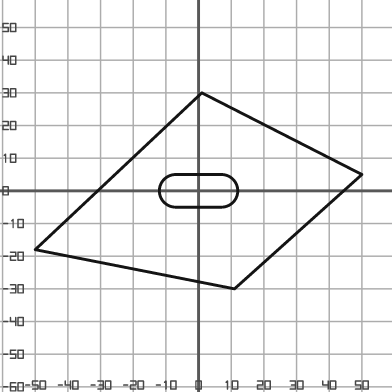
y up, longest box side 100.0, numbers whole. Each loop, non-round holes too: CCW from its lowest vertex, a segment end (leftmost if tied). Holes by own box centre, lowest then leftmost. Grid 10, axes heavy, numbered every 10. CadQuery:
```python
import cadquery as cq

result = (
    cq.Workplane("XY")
    .moveTo(11.0, -30.0)
    .lineTo(50.0, 5.0)
    .lineTo(1.0, 30.0)
    .lineTo(-50.0, -18.0)
    .close()
    .moveTo(-7.0, -5.0)
    .lineTo(7.0, -5.0)
    .threePointArc((12.0, 0.0), (7.0, 5.0))
    .lineTo(-7.0, 5.0)
    .threePointArc((-12.0, 0.0), (-7.0, -5.0))
    .close()
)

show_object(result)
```